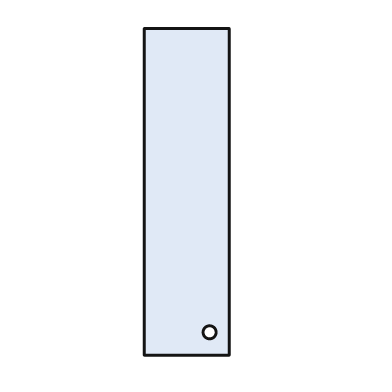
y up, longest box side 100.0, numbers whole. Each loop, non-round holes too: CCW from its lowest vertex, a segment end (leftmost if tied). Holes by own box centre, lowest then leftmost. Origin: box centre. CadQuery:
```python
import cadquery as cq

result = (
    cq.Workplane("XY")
    .moveTo(-13.0, -50.0)
    .lineTo(13.0, -50.0)
    .lineTo(13.0, 50.0)
    .lineTo(-13.0, 50.0)
    .close()
    .moveTo(7.0, -43.0)
    .circle(2.0)
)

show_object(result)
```